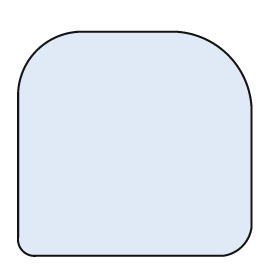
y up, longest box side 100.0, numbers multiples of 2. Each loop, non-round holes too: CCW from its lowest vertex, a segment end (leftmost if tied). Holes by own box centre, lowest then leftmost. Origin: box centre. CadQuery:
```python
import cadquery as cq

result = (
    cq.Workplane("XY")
    .moveTo(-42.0, -48.0)
    .lineTo(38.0, -48.0)
    .threePointArc((46.0, -44.0), (50.0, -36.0))
    .lineTo(50.0, 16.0)
    .threePointArc((40.0, 38.0), (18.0, 48.0))
    .lineTo(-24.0, 48.0)
    .threePointArc((-42.0, 40.0), (-50.0, 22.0))
    .lineTo(-50.0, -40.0)
    .threePointArc((-48.0, -46.0), (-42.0, -48.0))
    .close()
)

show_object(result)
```